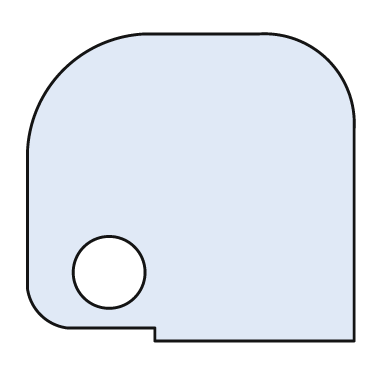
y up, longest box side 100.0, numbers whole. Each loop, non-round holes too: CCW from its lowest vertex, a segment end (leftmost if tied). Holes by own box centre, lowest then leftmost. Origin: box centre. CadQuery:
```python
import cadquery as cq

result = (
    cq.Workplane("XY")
    .moveTo(-11.0, -47.0)
    .lineTo(50.0, -47.0)
    .lineTo(50.0, 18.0)
    .threePointArc((42.0, 39.0), (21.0, 47.0))
    .lineTo(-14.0, 47.0)
    .threePointArc((-39.0, 36.0), (-50.0, 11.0))
    .lineTo(-50.0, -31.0)
    .threePointArc((-46.0, -39.0), (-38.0, -43.0))
    .lineTo(-11.0, -43.0)
    .close()
    .moveTo(-25.0, -26.0)
    .circle(11.0)
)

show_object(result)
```